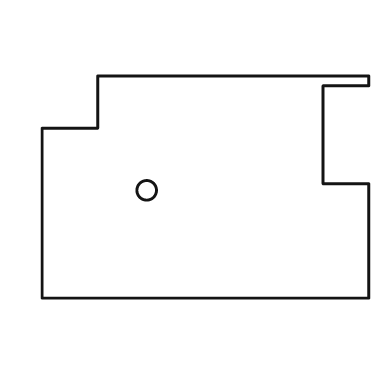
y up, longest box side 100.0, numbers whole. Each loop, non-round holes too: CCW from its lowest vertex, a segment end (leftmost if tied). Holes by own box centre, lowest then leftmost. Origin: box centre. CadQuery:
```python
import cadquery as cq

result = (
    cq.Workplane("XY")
    .moveTo(-50.0, -34.0)
    .lineTo(50.0, -34.0)
    .lineTo(50.0, 1.0)
    .lineTo(36.0, 1.0)
    .lineTo(36.0, 31.0)
    .lineTo(50.0, 31.0)
    .lineTo(50.0, 34.0)
    .lineTo(-33.0, 34.0)
    .lineTo(-33.0, 18.0)
    .lineTo(-50.0, 18.0)
    .close()
    .moveTo(-18.0, -1.0)
    .circle(3.0)
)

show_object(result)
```